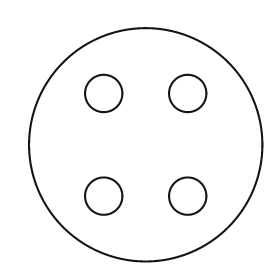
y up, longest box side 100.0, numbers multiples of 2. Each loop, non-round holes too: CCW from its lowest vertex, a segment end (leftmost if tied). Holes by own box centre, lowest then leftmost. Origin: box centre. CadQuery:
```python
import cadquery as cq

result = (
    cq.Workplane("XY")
    .moveTo(0.0, 0.0)
    .circle(50.0)
    .moveTo(-18.0, -22.0)
    .circle(8.0)
    .moveTo(18.0, -22.0)
    .circle(8.0)
    .moveTo(-18.0, 22.0)
    .circle(8.0)
    .moveTo(18.0, 22.0)
    .circle(8.0)
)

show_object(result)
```